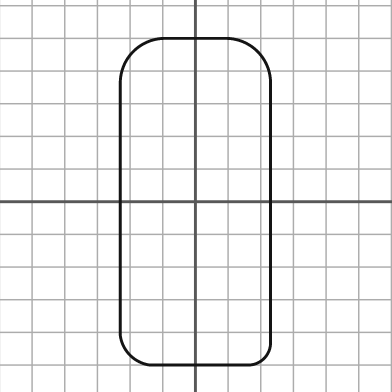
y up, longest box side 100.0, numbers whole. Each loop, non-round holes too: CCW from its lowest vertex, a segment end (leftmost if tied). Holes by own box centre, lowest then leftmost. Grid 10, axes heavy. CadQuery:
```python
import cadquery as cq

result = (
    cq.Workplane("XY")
    .moveTo(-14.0, -50.0)
    .lineTo(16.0, -50.0)
    .threePointArc((21.0, -48.0), (23.0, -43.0))
    .lineTo(23.0, 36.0)
    .threePointArc((19.0, 46.0), (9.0, 50.0))
    .lineTo(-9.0, 50.0)
    .threePointArc((-19.0, 46.0), (-23.0, 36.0))
    .lineTo(-23.0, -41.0)
    .threePointArc((-20.0, -47.0), (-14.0, -50.0))
    .close()
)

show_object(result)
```